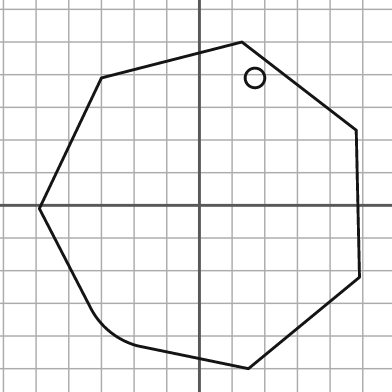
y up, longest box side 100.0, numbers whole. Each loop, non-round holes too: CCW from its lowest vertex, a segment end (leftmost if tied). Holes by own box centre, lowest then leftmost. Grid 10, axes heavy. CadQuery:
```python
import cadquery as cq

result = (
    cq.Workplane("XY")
    .moveTo(15.0, -50.0)
    .lineTo(49.0, -22.0)
    .lineTo(48.0, 23.0)
    .lineTo(13.0, 50.0)
    .lineTo(-30.0, 39.0)
    .lineTo(-49.0, -1.0)
    .lineTo(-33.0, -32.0)
    .threePointArc((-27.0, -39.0), (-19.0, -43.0))
    .close()
    .moveTo(17.0, 39.0)
    .circle(3.0)
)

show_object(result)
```